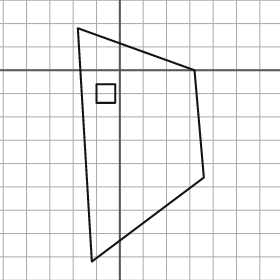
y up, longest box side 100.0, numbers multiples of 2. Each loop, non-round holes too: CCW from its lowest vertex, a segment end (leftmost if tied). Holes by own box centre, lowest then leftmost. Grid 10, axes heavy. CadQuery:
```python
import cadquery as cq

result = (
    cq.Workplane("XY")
    .moveTo(-12.0, -82.0)
    .lineTo(36.0, -46.0)
    .lineTo(32.0, 0.0)
    .lineTo(-18.0, 18.0)
    .close()
    .moveTo(-10.0, -14.0)
    .lineTo(-2.0, -14.0)
    .lineTo(-2.0, -6.0)
    .lineTo(-10.0, -6.0)
    .close()
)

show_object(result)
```